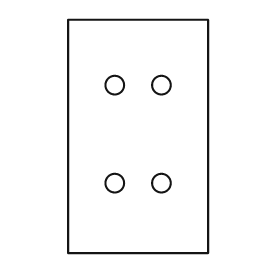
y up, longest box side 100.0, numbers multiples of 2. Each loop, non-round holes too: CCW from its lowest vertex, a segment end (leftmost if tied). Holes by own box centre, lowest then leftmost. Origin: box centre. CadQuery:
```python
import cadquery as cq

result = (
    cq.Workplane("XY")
    .moveTo(-30.0, -50.0)
    .lineTo(30.0, -50.0)
    .lineTo(30.0, 50.0)
    .lineTo(-30.0, 50.0)
    .close()
    .moveTo(-10.0, -20.0)
    .circle(4.0)
    .moveTo(10.0, -20.0)
    .circle(4.0)
    .moveTo(-10.0, 22.0)
    .circle(4.0)
    .moveTo(10.0, 22.0)
    .circle(4.0)
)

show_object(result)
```